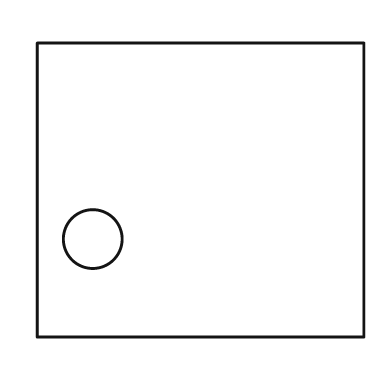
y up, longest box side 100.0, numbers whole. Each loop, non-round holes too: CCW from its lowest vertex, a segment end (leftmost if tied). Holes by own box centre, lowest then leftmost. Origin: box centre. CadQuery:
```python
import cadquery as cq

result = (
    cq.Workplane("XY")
    .moveTo(-50.0, -45.0)
    .lineTo(50.0, -45.0)
    .lineTo(50.0, 45.0)
    .lineTo(-50.0, 45.0)
    .close()
    .moveTo(-33.0, -15.0)
    .circle(9.0)
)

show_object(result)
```